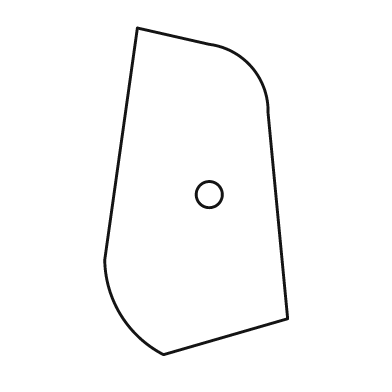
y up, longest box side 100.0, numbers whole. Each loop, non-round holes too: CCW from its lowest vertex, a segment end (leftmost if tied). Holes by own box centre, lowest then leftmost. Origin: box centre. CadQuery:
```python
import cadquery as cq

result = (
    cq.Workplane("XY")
    .moveTo(-10.0, -50.0)
    .lineTo(28.0, -39.0)
    .lineTo(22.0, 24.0)
    .threePointArc((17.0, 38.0), (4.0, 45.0))
    .lineTo(-18.0, 50.0)
    .lineTo(-28.0, -21.0)
    .threePointArc((-23.0, -38.0), (-10.0, -50.0))
    .close()
    .moveTo(4.0, -1.0)
    .circle(4.0)
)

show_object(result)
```